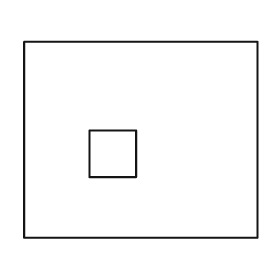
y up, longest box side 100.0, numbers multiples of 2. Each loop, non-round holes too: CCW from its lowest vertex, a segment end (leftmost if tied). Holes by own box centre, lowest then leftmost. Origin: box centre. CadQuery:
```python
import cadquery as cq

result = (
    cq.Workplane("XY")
    .moveTo(-50.0, -42.0)
    .lineTo(50.0, -42.0)
    .lineTo(50.0, 42.0)
    .lineTo(-50.0, 42.0)
    .close()
    .moveTo(-22.0, -16.0)
    .lineTo(-2.0, -16.0)
    .lineTo(-2.0, 4.0)
    .lineTo(-22.0, 4.0)
    .close()
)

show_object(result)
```